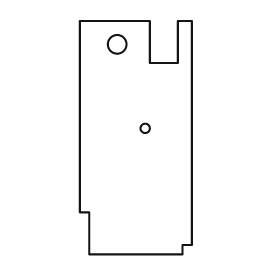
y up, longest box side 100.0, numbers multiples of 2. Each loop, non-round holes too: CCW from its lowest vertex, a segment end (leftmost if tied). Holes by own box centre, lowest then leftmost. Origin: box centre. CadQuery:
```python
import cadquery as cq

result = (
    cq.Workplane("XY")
    .moveTo(-20.0, -50.0)
    .lineTo(20.0, -50.0)
    .lineTo(20.0, -46.0)
    .lineTo(24.0, -46.0)
    .lineTo(24.0, 50.0)
    .lineTo(18.0, 50.0)
    .lineTo(18.0, 32.0)
    .lineTo(6.0, 32.0)
    .lineTo(6.0, 50.0)
    .lineTo(-24.0, 50.0)
    .lineTo(-24.0, -32.0)
    .lineTo(-20.0, -32.0)
    .close()
    .moveTo(4.0, 4.0)
    .circle(2.0)
    .moveTo(-8.0, 40.0)
    .circle(4.0)
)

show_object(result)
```